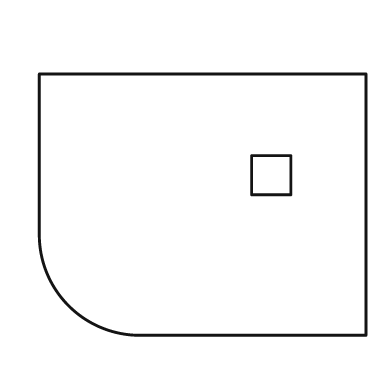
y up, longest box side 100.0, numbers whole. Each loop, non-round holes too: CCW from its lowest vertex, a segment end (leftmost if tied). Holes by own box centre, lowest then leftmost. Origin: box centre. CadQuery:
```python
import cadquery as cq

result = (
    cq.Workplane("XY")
    .moveTo(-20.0, -40.0)
    .lineTo(50.0, -40.0)
    .lineTo(50.0, 40.0)
    .lineTo(-50.0, 40.0)
    .lineTo(-50.0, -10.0)
    .threePointArc((-41.0, -31.0), (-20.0, -40.0))
    .close()
    .moveTo(15.0, 3.0)
    .lineTo(27.0, 3.0)
    .lineTo(27.0, 15.0)
    .lineTo(15.0, 15.0)
    .close()
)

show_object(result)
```